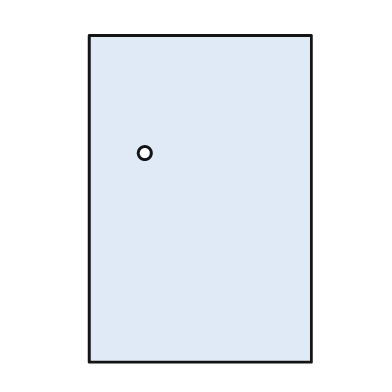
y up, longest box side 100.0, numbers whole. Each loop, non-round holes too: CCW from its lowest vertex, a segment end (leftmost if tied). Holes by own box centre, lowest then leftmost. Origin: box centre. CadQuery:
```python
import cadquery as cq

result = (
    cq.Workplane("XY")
    .moveTo(-34.0, -50.0)
    .lineTo(34.0, -50.0)
    .lineTo(34.0, 50.0)
    .lineTo(-34.0, 50.0)
    .close()
    .moveTo(-17.0, 14.0)
    .circle(2.0)
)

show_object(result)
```